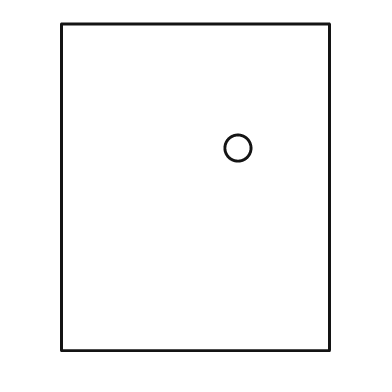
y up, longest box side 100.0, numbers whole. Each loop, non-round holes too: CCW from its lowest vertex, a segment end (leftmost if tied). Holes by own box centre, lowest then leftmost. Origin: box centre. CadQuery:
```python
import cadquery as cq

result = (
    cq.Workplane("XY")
    .moveTo(-41.0, -50.0)
    .lineTo(41.0, -50.0)
    .lineTo(41.0, 50.0)
    .lineTo(-41.0, 50.0)
    .close()
    .moveTo(13.0, 12.0)
    .circle(4.0)
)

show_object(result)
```